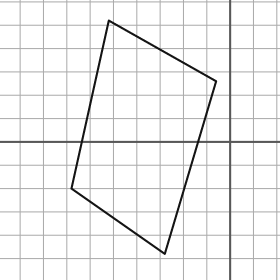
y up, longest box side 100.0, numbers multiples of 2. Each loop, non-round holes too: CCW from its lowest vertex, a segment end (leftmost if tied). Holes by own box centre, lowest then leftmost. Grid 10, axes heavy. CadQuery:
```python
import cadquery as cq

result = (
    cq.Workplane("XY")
    .moveTo(-28.0, -48.0)
    .lineTo(-6.0, 26.0)
    .lineTo(-52.0, 52.0)
    .lineTo(-68.0, -20.0)
    .close()
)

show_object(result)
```